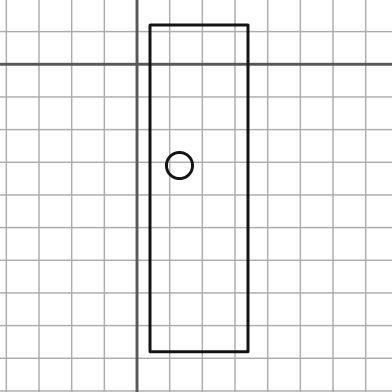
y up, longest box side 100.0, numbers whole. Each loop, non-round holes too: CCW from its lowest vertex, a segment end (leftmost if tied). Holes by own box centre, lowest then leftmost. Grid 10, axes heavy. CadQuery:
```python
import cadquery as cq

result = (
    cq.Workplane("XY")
    .moveTo(4.0, -88.0)
    .lineTo(34.0, -88.0)
    .lineTo(34.0, 12.0)
    .lineTo(4.0, 12.0)
    .close()
    .moveTo(13.0, -31.0)
    .circle(4.0)
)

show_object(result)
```